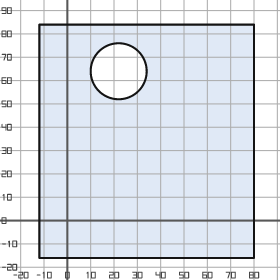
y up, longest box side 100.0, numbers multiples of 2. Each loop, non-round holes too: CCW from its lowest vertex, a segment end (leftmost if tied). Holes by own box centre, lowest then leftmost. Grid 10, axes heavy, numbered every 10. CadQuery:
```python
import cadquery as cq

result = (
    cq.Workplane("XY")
    .moveTo(-12.0, -16.0)
    .lineTo(80.0, -16.0)
    .lineTo(80.0, 84.0)
    .lineTo(-12.0, 84.0)
    .close()
    .moveTo(22.0, 64.0)
    .circle(12.0)
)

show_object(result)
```